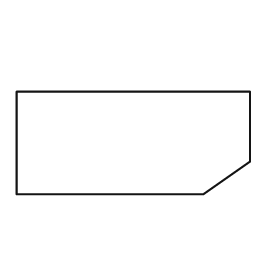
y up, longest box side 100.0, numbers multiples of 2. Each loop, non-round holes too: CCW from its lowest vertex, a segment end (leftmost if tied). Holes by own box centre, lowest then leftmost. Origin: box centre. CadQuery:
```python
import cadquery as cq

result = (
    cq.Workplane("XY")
    .moveTo(-50.0, -22.0)
    .lineTo(30.0, -22.0)
    .lineTo(50.0, -8.0)
    .lineTo(50.0, 22.0)
    .lineTo(-50.0, 22.0)
    .close()
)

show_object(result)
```